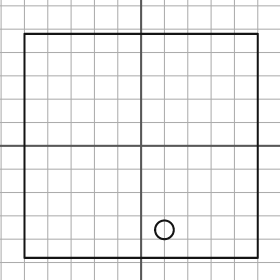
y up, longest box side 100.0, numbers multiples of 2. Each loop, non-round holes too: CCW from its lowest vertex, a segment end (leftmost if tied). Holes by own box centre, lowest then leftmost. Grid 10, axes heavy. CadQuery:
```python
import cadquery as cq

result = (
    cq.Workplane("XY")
    .moveTo(-50.0, -48.0)
    .lineTo(50.0, -48.0)
    .lineTo(50.0, 48.0)
    .lineTo(-50.0, 48.0)
    .close()
    .moveTo(10.0, -36.0)
    .circle(4.0)
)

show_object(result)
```